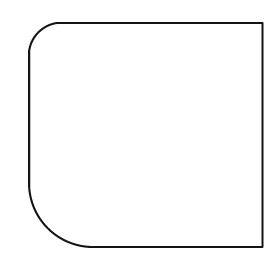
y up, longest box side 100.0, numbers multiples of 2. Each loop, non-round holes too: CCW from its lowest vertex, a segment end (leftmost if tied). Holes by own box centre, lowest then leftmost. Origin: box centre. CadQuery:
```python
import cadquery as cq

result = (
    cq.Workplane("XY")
    .moveTo(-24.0, -48.0)
    .lineTo(50.0, -48.0)
    .lineTo(50.0, 48.0)
    .lineTo(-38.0, 48.0)
    .threePointArc((-46.0, 44.0), (-50.0, 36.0))
    .lineTo(-50.0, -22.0)
    .threePointArc((-42.0, -40.0), (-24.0, -48.0))
    .close()
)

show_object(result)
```